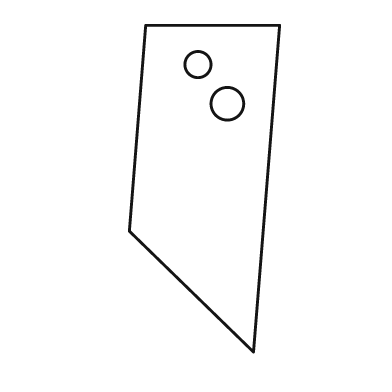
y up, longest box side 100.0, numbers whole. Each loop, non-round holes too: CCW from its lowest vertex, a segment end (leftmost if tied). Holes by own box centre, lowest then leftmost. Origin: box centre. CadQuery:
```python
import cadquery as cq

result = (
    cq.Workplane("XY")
    .moveTo(15.0, -50.0)
    .lineTo(23.0, 50.0)
    .lineTo(-18.0, 50.0)
    .lineTo(-23.0, -13.0)
    .close()
    .moveTo(7.0, 26.0)
    .circle(5.0)
    .moveTo(-2.0, 38.0)
    .circle(4.0)
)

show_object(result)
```